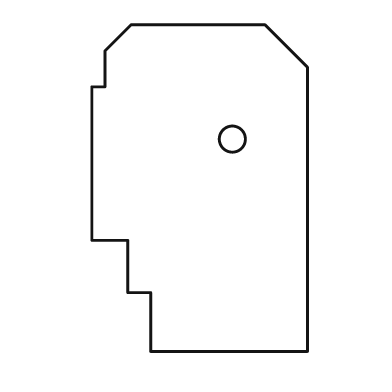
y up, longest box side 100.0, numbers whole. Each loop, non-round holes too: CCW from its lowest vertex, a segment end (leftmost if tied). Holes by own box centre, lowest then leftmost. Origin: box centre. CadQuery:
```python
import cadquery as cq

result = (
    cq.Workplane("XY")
    .moveTo(-15.0, -50.0)
    .lineTo(33.0, -50.0)
    .lineTo(33.0, 37.0)
    .lineTo(20.0, 50.0)
    .lineTo(-21.0, 50.0)
    .lineTo(-29.0, 42.0)
    .lineTo(-29.0, 31.0)
    .lineTo(-33.0, 31.0)
    .lineTo(-33.0, -16.0)
    .lineTo(-22.0, -16.0)
    .lineTo(-22.0, -32.0)
    .lineTo(-15.0, -32.0)
    .close()
    .moveTo(10.0, 15.0)
    .circle(4.0)
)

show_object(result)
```